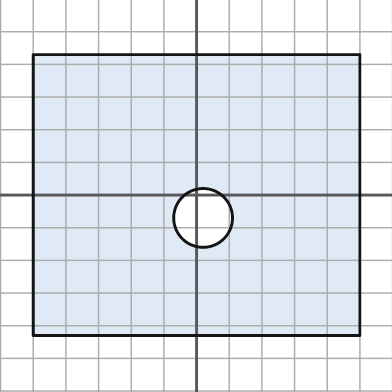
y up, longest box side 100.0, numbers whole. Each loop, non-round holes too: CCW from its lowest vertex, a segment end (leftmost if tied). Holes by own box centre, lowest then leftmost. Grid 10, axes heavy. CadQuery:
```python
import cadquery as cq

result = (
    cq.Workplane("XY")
    .moveTo(-50.0, -43.0)
    .lineTo(50.0, -43.0)
    .lineTo(50.0, 43.0)
    .lineTo(-50.0, 43.0)
    .close()
    .moveTo(2.0, -7.0)
    .circle(9.0)
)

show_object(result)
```